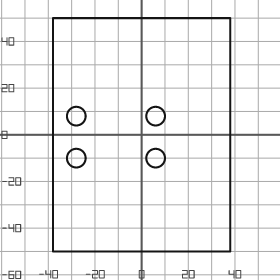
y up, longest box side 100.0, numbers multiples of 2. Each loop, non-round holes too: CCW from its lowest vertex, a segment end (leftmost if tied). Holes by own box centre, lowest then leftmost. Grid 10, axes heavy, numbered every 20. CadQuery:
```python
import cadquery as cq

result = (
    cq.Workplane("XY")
    .moveTo(-38.0, -50.0)
    .lineTo(38.0, -50.0)
    .lineTo(38.0, 50.0)
    .lineTo(-38.0, 50.0)
    .close()
    .moveTo(-28.0, -10.0)
    .circle(4.0)
    .moveTo(6.0, -10.0)
    .circle(4.0)
    .moveTo(-28.0, 8.0)
    .circle(4.0)
    .moveTo(6.0, 8.0)
    .circle(4.0)
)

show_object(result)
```